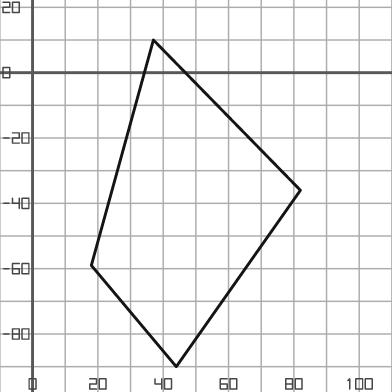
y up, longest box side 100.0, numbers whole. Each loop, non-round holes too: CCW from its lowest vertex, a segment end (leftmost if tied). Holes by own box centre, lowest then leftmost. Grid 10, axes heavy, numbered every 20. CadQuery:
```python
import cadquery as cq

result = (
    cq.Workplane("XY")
    .moveTo(44.0, -90.0)
    .lineTo(82.0, -36.0)
    .lineTo(37.0, 10.0)
    .lineTo(18.0, -59.0)
    .close()
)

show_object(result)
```